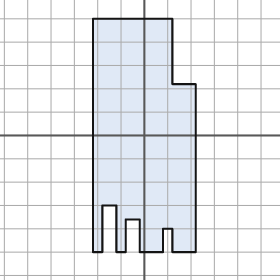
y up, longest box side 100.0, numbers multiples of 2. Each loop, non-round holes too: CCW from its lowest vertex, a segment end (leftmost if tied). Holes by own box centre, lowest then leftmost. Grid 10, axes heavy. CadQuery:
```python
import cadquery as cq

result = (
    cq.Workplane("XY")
    .moveTo(-22.0, -50.0)
    .lineTo(-18.0, -50.0)
    .lineTo(-18.0, -30.0)
    .lineTo(-12.0, -30.0)
    .lineTo(-12.0, -50.0)
    .lineTo(-8.0, -50.0)
    .lineTo(-8.0, -36.0)
    .lineTo(-2.0, -36.0)
    .lineTo(-2.0, -50.0)
    .lineTo(8.0, -50.0)
    .lineTo(8.0, -40.0)
    .lineTo(12.0, -40.0)
    .lineTo(12.0, -50.0)
    .lineTo(22.0, -50.0)
    .lineTo(22.0, 22.0)
    .lineTo(12.0, 22.0)
    .lineTo(12.0, 50.0)
    .lineTo(-22.0, 50.0)
    .close()
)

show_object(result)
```